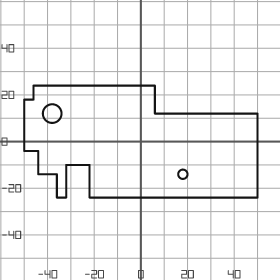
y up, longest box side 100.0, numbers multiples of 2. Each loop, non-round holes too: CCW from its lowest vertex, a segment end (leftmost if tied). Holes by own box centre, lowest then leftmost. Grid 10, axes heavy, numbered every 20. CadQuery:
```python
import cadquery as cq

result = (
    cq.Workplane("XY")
    .moveTo(-36.0, -24.0)
    .lineTo(-32.0, -24.0)
    .lineTo(-32.0, -10.0)
    .lineTo(-22.0, -10.0)
    .lineTo(-22.0, -24.0)
    .lineTo(50.0, -24.0)
    .lineTo(50.0, 12.0)
    .lineTo(6.0, 12.0)
    .lineTo(6.0, 24.0)
    .lineTo(-46.0, 24.0)
    .lineTo(-46.0, 18.0)
    .lineTo(-50.0, 18.0)
    .lineTo(-50.0, -4.0)
    .lineTo(-44.0, -4.0)
    .lineTo(-44.0, -14.0)
    .lineTo(-36.0, -14.0)
    .close()
    .moveTo(18.0, -14.0)
    .circle(2.0)
    .moveTo(-38.0, 12.0)
    .circle(4.0)
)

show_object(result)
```